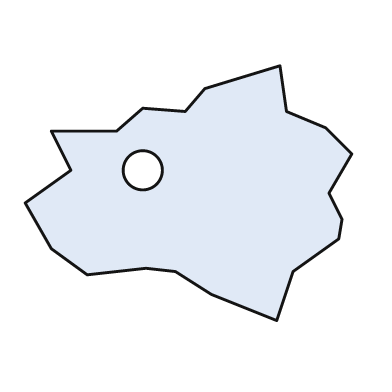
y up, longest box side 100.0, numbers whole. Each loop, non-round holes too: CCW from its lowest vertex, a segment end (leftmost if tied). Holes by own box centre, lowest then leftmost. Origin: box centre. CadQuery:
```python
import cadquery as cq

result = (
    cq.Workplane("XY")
    .moveTo(27.0, -39.0)
    .lineTo(32.0, -24.0)
    .lineTo(46.0, -14.0)
    .lineTo(47.0, -8.0)
    .lineTo(43.0, 0.0)
    .lineTo(50.0, 12.0)
    .lineTo(42.0, 20.0)
    .lineTo(30.0, 25.0)
    .lineTo(28.0, 39.0)
    .lineTo(5.0, 32.0)
    .lineTo(-1.0, 25.0)
    .lineTo(-14.0, 26.0)
    .lineTo(-22.0, 19.0)
    .lineTo(-42.0, 19.0)
    .lineTo(-36.0, 7.0)
    .lineTo(-50.0, -3.0)
    .lineTo(-42.0, -17.0)
    .lineTo(-31.0, -25.0)
    .lineTo(-13.0, -23.0)
    .lineTo(-4.0, -24.0)
    .lineTo(7.0, -31.0)
    .close()
    .moveTo(-14.0, 7.0)
    .circle(6.0)
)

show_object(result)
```